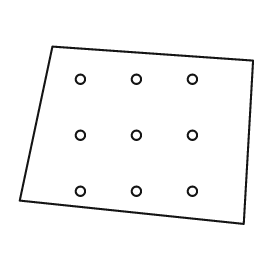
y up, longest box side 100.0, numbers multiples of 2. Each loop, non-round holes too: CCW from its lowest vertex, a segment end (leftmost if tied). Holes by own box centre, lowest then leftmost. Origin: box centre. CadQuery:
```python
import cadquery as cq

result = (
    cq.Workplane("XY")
    .moveTo(46.0, -38.0)
    .lineTo(50.0, 32.0)
    .lineTo(-36.0, 38.0)
    .lineTo(-50.0, -28.0)
    .close()
    .moveTo(-24.0, -24.0)
    .circle(2.0)
    .moveTo(0.0, -24.0)
    .circle(2.0)
    .moveTo(24.0, -24.0)
    .circle(2.0)
    .moveTo(-24.0, 0.0)
    .circle(2.0)
    .moveTo(0.0, 0.0)
    .circle(2.0)
    .moveTo(24.0, 0.0)
    .circle(2.0)
    .moveTo(-24.0, 24.0)
    .circle(2.0)
    .moveTo(0.0, 24.0)
    .circle(2.0)
    .moveTo(24.0, 24.0)
    .circle(2.0)
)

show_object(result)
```